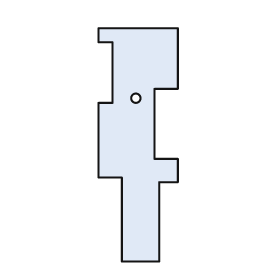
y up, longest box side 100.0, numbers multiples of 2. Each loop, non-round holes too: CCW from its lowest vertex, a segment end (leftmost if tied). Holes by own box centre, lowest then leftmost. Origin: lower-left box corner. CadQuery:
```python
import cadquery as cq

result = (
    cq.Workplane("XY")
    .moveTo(10.0, 0.0)
    .lineTo(26.0, 0.0)
    .lineTo(26.0, 34.0)
    .lineTo(34.0, 34.0)
    .lineTo(34.0, 44.0)
    .lineTo(24.0, 44.0)
    .lineTo(24.0, 74.0)
    .lineTo(34.0, 74.0)
    .lineTo(34.0, 100.0)
    .lineTo(0.0, 100.0)
    .lineTo(0.0, 94.0)
    .lineTo(6.0, 94.0)
    .lineTo(6.0, 68.0)
    .lineTo(0.0, 68.0)
    .lineTo(0.0, 36.0)
    .lineTo(10.0, 36.0)
    .close()
    .moveTo(16.0, 70.0)
    .circle(2.0)
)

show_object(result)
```